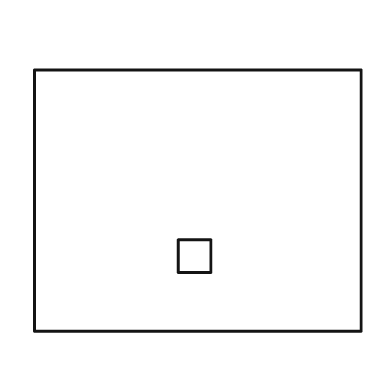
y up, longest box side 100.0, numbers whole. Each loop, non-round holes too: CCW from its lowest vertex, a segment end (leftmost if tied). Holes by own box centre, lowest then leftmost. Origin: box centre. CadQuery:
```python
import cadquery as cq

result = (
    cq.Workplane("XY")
    .moveTo(-50.0, -40.0)
    .lineTo(50.0, -40.0)
    .lineTo(50.0, 40.0)
    .lineTo(-50.0, 40.0)
    .close()
    .moveTo(-6.0, -22.0)
    .lineTo(4.0, -22.0)
    .lineTo(4.0, -12.0)
    .lineTo(-6.0, -12.0)
    .close()
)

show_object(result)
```